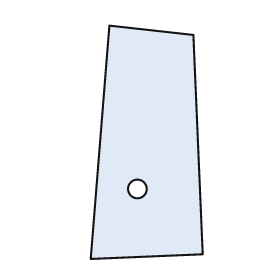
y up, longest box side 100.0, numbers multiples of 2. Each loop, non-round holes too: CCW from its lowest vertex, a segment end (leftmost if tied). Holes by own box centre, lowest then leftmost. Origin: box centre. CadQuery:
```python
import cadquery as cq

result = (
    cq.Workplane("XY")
    .moveTo(-24.0, -50.0)
    .lineTo(24.0, -48.0)
    .lineTo(20.0, 46.0)
    .lineTo(-16.0, 50.0)
    .close()
    .moveTo(-4.0, -20.0)
    .circle(4.0)
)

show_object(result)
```